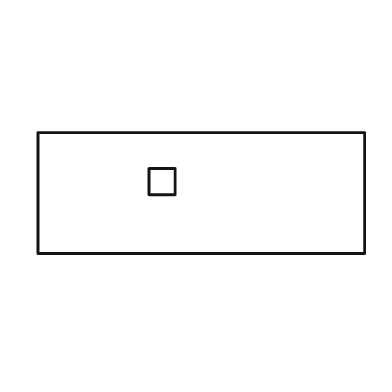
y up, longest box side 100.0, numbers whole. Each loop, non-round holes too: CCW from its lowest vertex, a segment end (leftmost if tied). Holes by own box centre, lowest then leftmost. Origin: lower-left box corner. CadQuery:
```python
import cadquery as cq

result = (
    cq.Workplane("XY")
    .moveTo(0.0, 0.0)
    .lineTo(100.0, 0.0)
    .lineTo(100.0, 37.0)
    .lineTo(0.0, 37.0)
    .close()
    .moveTo(34.0, 18.0)
    .lineTo(42.0, 18.0)
    .lineTo(42.0, 26.0)
    .lineTo(34.0, 26.0)
    .close()
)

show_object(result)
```